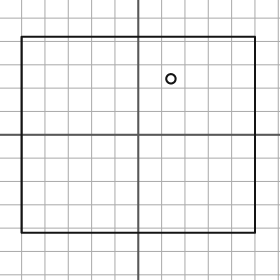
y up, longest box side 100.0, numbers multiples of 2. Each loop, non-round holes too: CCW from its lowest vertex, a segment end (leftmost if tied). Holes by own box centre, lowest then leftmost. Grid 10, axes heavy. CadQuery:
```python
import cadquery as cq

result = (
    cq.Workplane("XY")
    .moveTo(-50.0, -42.0)
    .lineTo(50.0, -42.0)
    .lineTo(50.0, 42.0)
    .lineTo(-50.0, 42.0)
    .close()
    .moveTo(14.0, 24.0)
    .circle(2.0)
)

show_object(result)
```